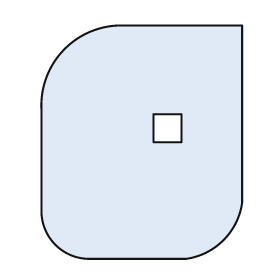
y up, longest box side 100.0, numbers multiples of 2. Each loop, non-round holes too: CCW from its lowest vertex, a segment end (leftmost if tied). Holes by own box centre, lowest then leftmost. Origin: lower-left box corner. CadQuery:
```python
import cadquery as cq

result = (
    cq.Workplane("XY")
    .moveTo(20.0, 0.0)
    .lineTo(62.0, 0.0)
    .threePointArc((78.0, 8.0), (86.0, 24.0))
    .lineTo(86.0, 100.0)
    .lineTo(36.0, 100.0)
    .threePointArc((10.0, 90.0), (0.0, 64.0))
    .lineTo(0.0, 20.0)
    .threePointArc((6.0, 6.0), (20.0, 0.0))
    .close()
    .moveTo(48.0, 50.0)
    .lineTo(60.0, 50.0)
    .lineTo(60.0, 62.0)
    .lineTo(48.0, 62.0)
    .close()
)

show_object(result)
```